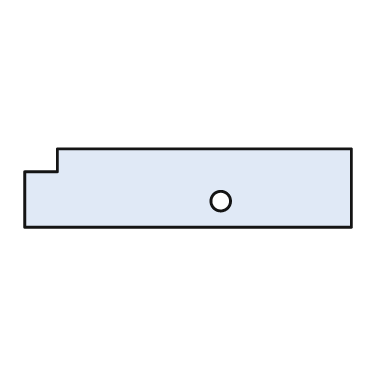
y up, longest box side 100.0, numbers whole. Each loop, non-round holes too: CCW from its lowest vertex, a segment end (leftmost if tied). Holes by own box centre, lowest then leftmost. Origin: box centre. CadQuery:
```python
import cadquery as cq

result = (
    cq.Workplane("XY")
    .moveTo(-50.0, -12.0)
    .lineTo(50.0, -12.0)
    .lineTo(50.0, 12.0)
    .lineTo(-40.0, 12.0)
    .lineTo(-40.0, 5.0)
    .lineTo(-50.0, 5.0)
    .close()
    .moveTo(10.0, -4.0)
    .circle(3.0)
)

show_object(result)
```